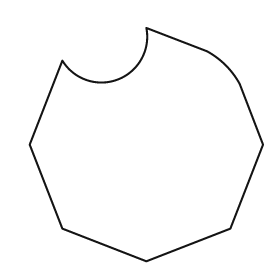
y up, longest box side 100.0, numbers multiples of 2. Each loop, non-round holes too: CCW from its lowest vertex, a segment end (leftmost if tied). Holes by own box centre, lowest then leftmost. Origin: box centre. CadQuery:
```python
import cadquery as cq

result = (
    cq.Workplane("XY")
    .moveTo(0.0, -50.0)
    .lineTo(36.0, -36.0)
    .lineTo(50.0, 0.0)
    .lineTo(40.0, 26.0)
    .threePointArc((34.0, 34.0), (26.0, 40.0))
    .lineTo(0.0, 50.0)
    .threePointArc((-12.0, 28.0), (-36.0, 36.0))
    .lineTo(-50.0, 0.0)
    .lineTo(-36.0, -36.0)
    .close()
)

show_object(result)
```